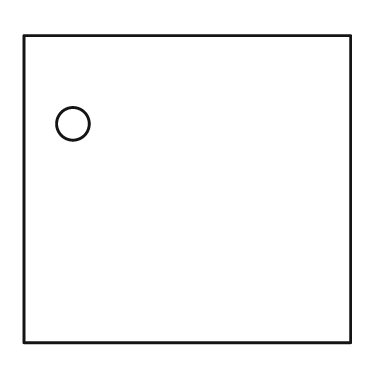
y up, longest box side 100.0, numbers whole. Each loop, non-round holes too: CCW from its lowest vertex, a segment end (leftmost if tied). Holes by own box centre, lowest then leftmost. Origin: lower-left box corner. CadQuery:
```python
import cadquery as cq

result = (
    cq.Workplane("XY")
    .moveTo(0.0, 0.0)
    .lineTo(100.0, 0.0)
    .lineTo(100.0, 94.0)
    .lineTo(0.0, 94.0)
    .close()
    .moveTo(15.0, 67.0)
    .circle(5.0)
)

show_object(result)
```